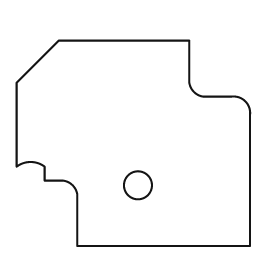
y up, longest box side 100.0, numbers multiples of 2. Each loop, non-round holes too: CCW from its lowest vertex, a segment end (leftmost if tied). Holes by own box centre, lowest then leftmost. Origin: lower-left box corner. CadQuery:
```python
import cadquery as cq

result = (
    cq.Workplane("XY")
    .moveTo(26.0, 0.0)
    .lineTo(100.0, 0.0)
    .lineTo(100.0, 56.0)
    .threePointArc((98.0, 62.0), (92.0, 64.0))
    .lineTo(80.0, 64.0)
    .threePointArc((76.0, 66.0), (74.0, 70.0))
    .lineTo(74.0, 88.0)
    .lineTo(18.0, 88.0)
    .lineTo(0.0, 70.0)
    .lineTo(0.0, 34.0)
    .threePointArc((6.0, 36.0), (12.0, 34.0))
    .lineTo(12.0, 28.0)
    .lineTo(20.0, 28.0)
    .threePointArc((24.0, 26.0), (26.0, 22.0))
    .close()
    .moveTo(52.0, 26.0)
    .circle(6.0)
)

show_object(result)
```